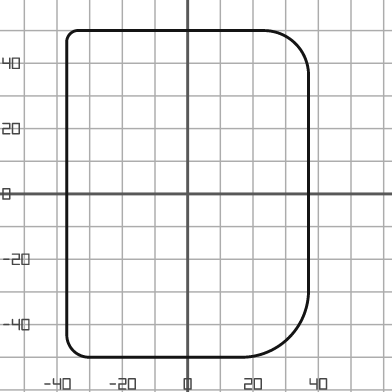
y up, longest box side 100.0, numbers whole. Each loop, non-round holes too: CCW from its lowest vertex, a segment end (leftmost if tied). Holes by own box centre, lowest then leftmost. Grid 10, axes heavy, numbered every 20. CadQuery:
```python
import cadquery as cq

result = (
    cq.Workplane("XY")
    .moveTo(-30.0, -50.0)
    .lineTo(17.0, -50.0)
    .threePointArc((31.0, -44.0), (37.0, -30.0))
    .lineTo(37.0, 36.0)
    .threePointArc((33.0, 46.0), (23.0, 50.0))
    .lineTo(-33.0, 50.0)
    .threePointArc((-36.0, 49.0), (-37.0, 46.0))
    .lineTo(-37.0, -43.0)
    .threePointArc((-35.0, -48.0), (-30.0, -50.0))
    .close()
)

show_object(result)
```